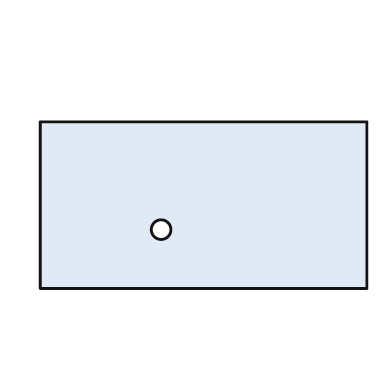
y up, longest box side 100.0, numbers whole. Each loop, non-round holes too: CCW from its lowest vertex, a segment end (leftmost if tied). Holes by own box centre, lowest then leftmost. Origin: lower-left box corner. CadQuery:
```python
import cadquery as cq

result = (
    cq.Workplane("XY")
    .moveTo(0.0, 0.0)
    .lineTo(100.0, 0.0)
    .lineTo(100.0, 51.0)
    .lineTo(0.0, 51.0)
    .close()
    .moveTo(37.0, 18.0)
    .circle(3.0)
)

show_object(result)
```